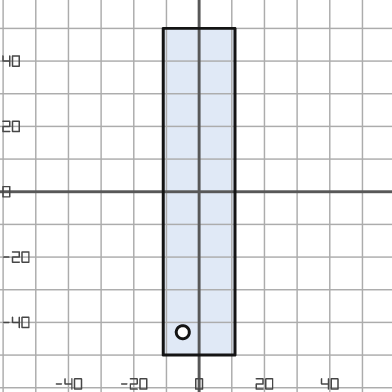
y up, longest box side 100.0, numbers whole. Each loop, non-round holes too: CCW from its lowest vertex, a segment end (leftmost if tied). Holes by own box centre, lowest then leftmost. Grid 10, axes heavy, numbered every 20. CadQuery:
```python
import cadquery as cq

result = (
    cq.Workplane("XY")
    .moveTo(-11.0, -50.0)
    .lineTo(11.0, -50.0)
    .lineTo(11.0, 50.0)
    .lineTo(-11.0, 50.0)
    .close()
    .moveTo(-5.0, -43.0)
    .circle(2.0)
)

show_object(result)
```